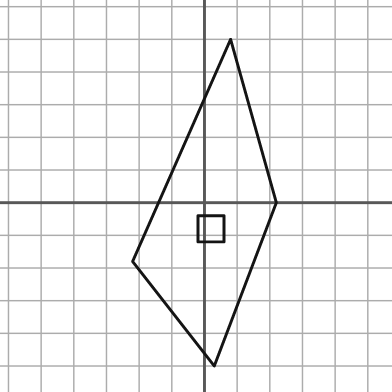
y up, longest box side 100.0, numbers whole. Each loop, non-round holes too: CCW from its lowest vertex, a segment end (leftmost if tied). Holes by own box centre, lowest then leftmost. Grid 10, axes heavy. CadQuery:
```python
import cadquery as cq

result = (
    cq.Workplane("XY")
    .moveTo(3.0, -50.0)
    .lineTo(22.0, 0.0)
    .lineTo(8.0, 50.0)
    .lineTo(-22.0, -18.0)
    .close()
    .moveTo(-2.0, -12.0)
    .lineTo(6.0, -12.0)
    .lineTo(6.0, -4.0)
    .lineTo(-2.0, -4.0)
    .close()
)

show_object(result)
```